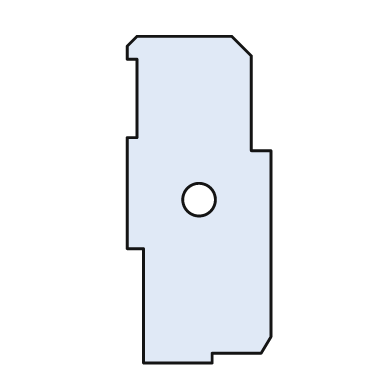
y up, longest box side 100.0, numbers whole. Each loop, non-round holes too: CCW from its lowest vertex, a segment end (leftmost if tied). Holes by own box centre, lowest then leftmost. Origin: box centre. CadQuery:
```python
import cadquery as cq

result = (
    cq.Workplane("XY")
    .moveTo(-17.0, -50.0)
    .lineTo(4.0, -50.0)
    .lineTo(4.0, -47.0)
    .lineTo(19.0, -47.0)
    .lineTo(22.0, -42.0)
    .lineTo(22.0, 15.0)
    .lineTo(16.0, 15.0)
    .lineTo(16.0, 44.0)
    .lineTo(10.0, 50.0)
    .lineTo(-19.0, 50.0)
    .lineTo(-22.0, 47.0)
    .lineTo(-22.0, 43.0)
    .lineTo(-19.0, 43.0)
    .lineTo(-19.0, 19.0)
    .lineTo(-22.0, 19.0)
    .lineTo(-22.0, -15.0)
    .lineTo(-17.0, -15.0)
    .close()
    .moveTo(0.0, 0.0)
    .circle(5.0)
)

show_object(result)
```